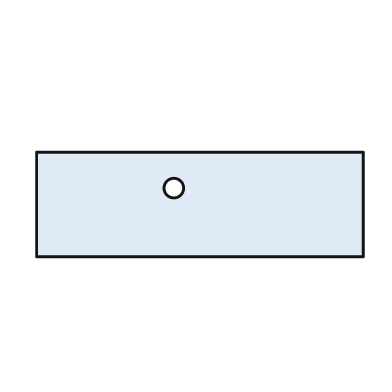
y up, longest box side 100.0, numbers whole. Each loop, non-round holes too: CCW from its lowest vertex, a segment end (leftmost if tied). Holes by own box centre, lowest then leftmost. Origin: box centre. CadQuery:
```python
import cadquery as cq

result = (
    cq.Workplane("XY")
    .moveTo(-50.0, -16.0)
    .lineTo(50.0, -16.0)
    .lineTo(50.0, 16.0)
    .lineTo(-50.0, 16.0)
    .close()
    .moveTo(-8.0, 5.0)
    .circle(3.0)
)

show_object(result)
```